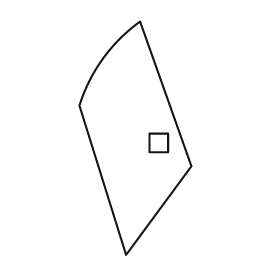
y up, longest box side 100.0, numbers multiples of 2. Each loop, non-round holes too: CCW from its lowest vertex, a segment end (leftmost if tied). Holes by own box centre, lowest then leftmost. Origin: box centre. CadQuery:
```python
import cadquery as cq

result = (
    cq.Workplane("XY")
    .moveTo(-4.0, -50.0)
    .lineTo(24.0, -12.0)
    .lineTo(2.0, 50.0)
    .threePointArc((-14.0, 34.0), (-24.0, 14.0))
    .close()
    .moveTo(6.0, -6.0)
    .lineTo(14.0, -6.0)
    .lineTo(14.0, 2.0)
    .lineTo(6.0, 2.0)
    .close()
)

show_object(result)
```